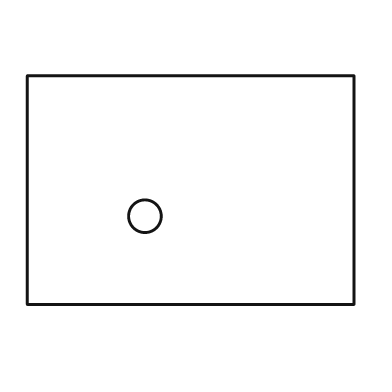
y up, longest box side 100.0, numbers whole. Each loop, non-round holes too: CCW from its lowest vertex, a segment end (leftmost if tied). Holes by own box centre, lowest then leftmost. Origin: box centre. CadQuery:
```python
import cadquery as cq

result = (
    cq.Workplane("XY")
    .moveTo(-50.0, -35.0)
    .lineTo(50.0, -35.0)
    .lineTo(50.0, 35.0)
    .lineTo(-50.0, 35.0)
    .close()
    .moveTo(-14.0, -8.0)
    .circle(5.0)
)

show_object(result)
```